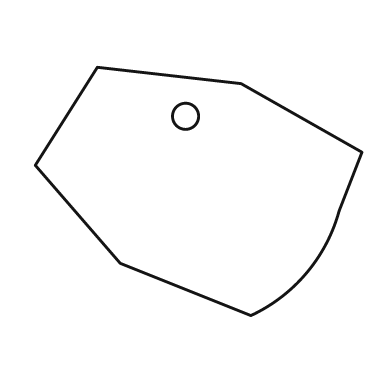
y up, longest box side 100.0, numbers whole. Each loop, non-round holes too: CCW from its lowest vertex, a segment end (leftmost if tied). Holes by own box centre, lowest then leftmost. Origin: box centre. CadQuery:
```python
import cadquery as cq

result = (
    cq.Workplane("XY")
    .moveTo(16.0, -38.0)
    .threePointArc((33.0, -25.0), (43.0, -6.0))
    .lineTo(50.0, 12.0)
    .lineTo(13.0, 33.0)
    .lineTo(-31.0, 38.0)
    .lineTo(-50.0, 8.0)
    .lineTo(-24.0, -22.0)
    .close()
    .moveTo(-4.0, 23.0)
    .circle(4.0)
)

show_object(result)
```